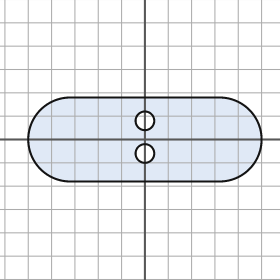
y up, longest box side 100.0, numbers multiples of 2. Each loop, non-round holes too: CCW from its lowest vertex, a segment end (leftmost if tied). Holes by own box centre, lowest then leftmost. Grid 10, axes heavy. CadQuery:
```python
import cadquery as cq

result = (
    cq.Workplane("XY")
    .moveTo(-32.0, -18.0)
    .lineTo(32.0, -18.0)
    .threePointArc((50.0, 0.0), (32.0, 18.0))
    .lineTo(-32.0, 18.0)
    .threePointArc((-50.0, 0.0), (-32.0, -18.0))
    .close()
    .moveTo(0.0, -6.0)
    .circle(4.0)
    .moveTo(0.0, 8.0)
    .circle(4.0)
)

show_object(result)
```